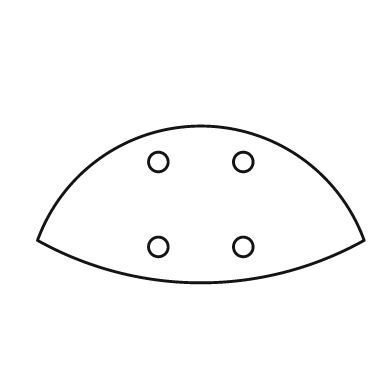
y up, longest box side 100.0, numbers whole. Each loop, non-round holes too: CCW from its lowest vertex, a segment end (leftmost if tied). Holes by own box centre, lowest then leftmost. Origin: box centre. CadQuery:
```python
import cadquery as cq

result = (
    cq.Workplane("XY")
    .moveTo(-50.0, -11.0)
    .threePointArc((0.0, -24.0), (50.0, -11.0))
    .threePointArc((0.0, 24.0), (-50.0, -11.0))
    .close()
    .moveTo(-13.0, -13.0)
    .circle(3.0)
    .moveTo(13.0, -13.0)
    .circle(3.0)
    .moveTo(-13.0, 13.0)
    .circle(3.0)
    .moveTo(13.0, 13.0)
    .circle(3.0)
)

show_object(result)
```